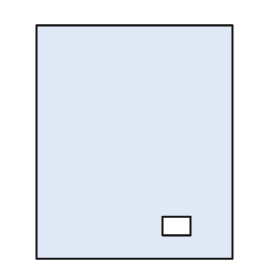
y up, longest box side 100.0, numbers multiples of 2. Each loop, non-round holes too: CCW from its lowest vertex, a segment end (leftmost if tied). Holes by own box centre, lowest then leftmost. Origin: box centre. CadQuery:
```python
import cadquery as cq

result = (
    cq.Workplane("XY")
    .moveTo(-42.0, -50.0)
    .lineTo(42.0, -50.0)
    .lineTo(42.0, 50.0)
    .lineTo(-42.0, 50.0)
    .close()
    .moveTo(12.0, -40.0)
    .lineTo(24.0, -40.0)
    .lineTo(24.0, -32.0)
    .lineTo(12.0, -32.0)
    .close()
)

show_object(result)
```